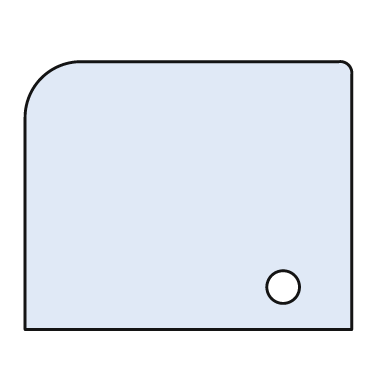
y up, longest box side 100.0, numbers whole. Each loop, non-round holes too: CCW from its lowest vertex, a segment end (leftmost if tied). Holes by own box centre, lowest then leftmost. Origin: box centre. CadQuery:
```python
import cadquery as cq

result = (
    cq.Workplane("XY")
    .moveTo(-50.0, -41.0)
    .lineTo(50.0, -41.0)
    .lineTo(50.0, 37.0)
    .threePointArc((49.0, 40.0), (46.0, 41.0))
    .lineTo(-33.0, 41.0)
    .threePointArc((-45.0, 36.0), (-50.0, 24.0))
    .close()
    .moveTo(29.0, -28.0)
    .circle(5.0)
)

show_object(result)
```